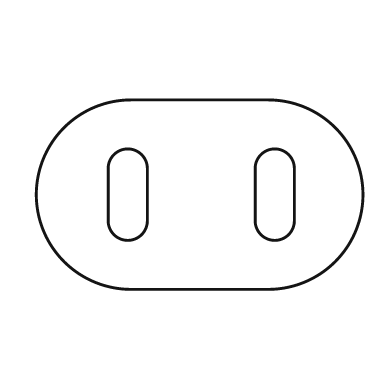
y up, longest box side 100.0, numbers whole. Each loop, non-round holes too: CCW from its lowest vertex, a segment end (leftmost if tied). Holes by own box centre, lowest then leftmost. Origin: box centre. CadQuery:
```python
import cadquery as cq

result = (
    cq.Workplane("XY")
    .moveTo(-21.0, -29.0)
    .lineTo(21.0, -29.0)
    .threePointArc((50.0, 0.0), (21.0, 29.0))
    .lineTo(-21.0, 29.0)
    .threePointArc((-50.0, 0.0), (-21.0, -29.0))
    .close()
    .moveTo(-28.0, -8.0)
    .threePointArc((-22.0, -14.0), (-16.0, -8.0))
    .lineTo(-16.0, 8.0)
    .threePointArc((-22.0, 14.0), (-28.0, 8.0))
    .close()
    .moveTo(17.0, -8.0)
    .threePointArc((23.0, -14.0), (29.0, -8.0))
    .lineTo(29.0, 8.0)
    .threePointArc((23.0, 14.0), (17.0, 8.0))
    .close()
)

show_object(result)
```